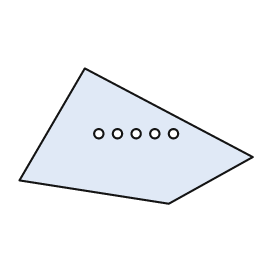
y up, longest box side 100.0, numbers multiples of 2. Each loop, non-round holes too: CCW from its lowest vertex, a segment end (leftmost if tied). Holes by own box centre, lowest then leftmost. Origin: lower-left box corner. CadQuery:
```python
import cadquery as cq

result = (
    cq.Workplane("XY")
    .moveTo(64.0, 0.0)
    .lineTo(100.0, 20.0)
    .lineTo(28.0, 58.0)
    .lineTo(0.0, 10.0)
    .close()
    .moveTo(34.0, 30.0)
    .circle(2.0)
    .moveTo(42.0, 30.0)
    .circle(2.0)
    .moveTo(50.0, 30.0)
    .circle(2.0)
    .moveTo(58.0, 30.0)
    .circle(2.0)
    .moveTo(66.0, 30.0)
    .circle(2.0)
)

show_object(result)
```